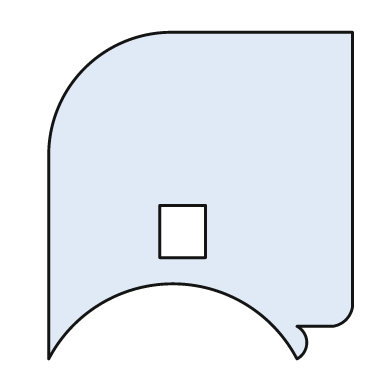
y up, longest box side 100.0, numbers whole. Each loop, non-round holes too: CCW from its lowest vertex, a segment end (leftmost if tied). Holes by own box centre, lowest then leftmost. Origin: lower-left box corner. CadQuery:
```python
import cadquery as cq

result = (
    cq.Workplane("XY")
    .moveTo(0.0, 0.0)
    .threePointArc((38.0, 23.0), (76.0, 0.0))
    .threePointArc((79.0, 5.0), (76.0, 10.0))
    .lineTo(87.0, 10.0)
    .threePointArc((91.0, 12.0), (93.0, 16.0))
    .lineTo(93.0, 100.0)
    .lineTo(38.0, 100.0)
    .threePointArc((11.0, 89.0), (0.0, 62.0))
    .close()
    .moveTo(34.0, 31.0)
    .lineTo(48.0, 31.0)
    .lineTo(48.0, 47.0)
    .lineTo(34.0, 47.0)
    .close()
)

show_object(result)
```